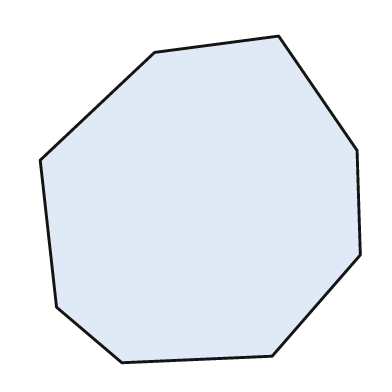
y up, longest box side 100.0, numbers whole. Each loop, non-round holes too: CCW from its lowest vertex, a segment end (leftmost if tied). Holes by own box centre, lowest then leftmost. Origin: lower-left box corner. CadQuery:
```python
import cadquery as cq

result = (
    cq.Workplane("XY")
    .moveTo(25.0, 0.0)
    .lineTo(71.0, 2.0)
    .lineTo(98.0, 33.0)
    .lineTo(97.0, 65.0)
    .lineTo(73.0, 100.0)
    .lineTo(35.0, 95.0)
    .lineTo(0.0, 62.0)
    .lineTo(5.0, 17.0)
    .close()
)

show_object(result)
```